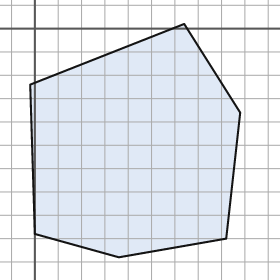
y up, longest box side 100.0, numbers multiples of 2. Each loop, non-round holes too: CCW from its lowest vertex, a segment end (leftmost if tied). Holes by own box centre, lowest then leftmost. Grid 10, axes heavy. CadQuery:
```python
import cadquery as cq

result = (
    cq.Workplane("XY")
    .moveTo(36.0, -98.0)
    .lineTo(82.0, -90.0)
    .lineTo(88.0, -36.0)
    .lineTo(64.0, 2.0)
    .lineTo(-2.0, -24.0)
    .lineTo(0.0, -88.0)
    .close()
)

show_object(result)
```